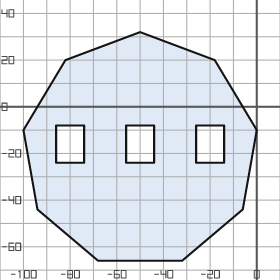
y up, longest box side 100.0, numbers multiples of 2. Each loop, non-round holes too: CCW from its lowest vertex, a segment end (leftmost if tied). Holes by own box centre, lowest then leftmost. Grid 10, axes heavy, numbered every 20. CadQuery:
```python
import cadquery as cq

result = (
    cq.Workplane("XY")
    .moveTo(-68.0, -66.0)
    .lineTo(-32.0, -66.0)
    .lineTo(-6.0, -44.0)
    .lineTo(0.0, -10.0)
    .lineTo(-18.0, 20.0)
    .lineTo(-50.0, 32.0)
    .lineTo(-82.0, 20.0)
    .lineTo(-100.0, -10.0)
    .lineTo(-94.0, -44.0)
    .close()
    .moveTo(-86.0, -24.0)
    .lineTo(-74.0, -24.0)
    .lineTo(-74.0, -8.0)
    .lineTo(-86.0, -8.0)
    .close()
    .moveTo(-56.0, -24.0)
    .lineTo(-44.0, -24.0)
    .lineTo(-44.0, -8.0)
    .lineTo(-56.0, -8.0)
    .close()
    .moveTo(-26.0, -24.0)
    .lineTo(-14.0, -24.0)
    .lineTo(-14.0, -8.0)
    .lineTo(-26.0, -8.0)
    .close()
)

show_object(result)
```